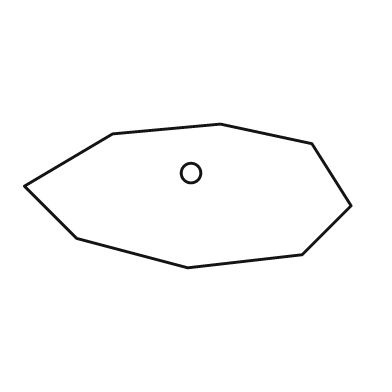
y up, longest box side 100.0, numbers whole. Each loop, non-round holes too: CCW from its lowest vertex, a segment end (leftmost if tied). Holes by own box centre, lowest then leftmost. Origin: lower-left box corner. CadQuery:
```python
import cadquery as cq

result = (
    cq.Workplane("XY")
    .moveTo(50.0, 0.0)
    .lineTo(85.0, 4.0)
    .lineTo(100.0, 19.0)
    .lineTo(88.0, 38.0)
    .lineTo(60.0, 44.0)
    .lineTo(27.0, 41.0)
    .lineTo(0.0, 25.0)
    .lineTo(16.0, 9.0)
    .close()
    .moveTo(51.0, 29.0)
    .circle(3.0)
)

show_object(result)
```